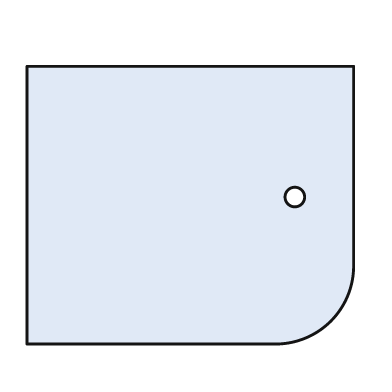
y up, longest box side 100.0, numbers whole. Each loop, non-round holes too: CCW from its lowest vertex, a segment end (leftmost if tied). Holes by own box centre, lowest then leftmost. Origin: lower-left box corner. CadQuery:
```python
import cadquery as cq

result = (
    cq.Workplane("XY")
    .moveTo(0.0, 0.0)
    .lineTo(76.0, 0.0)
    .threePointArc((93.0, 7.0), (100.0, 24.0))
    .lineTo(100.0, 85.0)
    .lineTo(0.0, 85.0)
    .close()
    .moveTo(82.0, 45.0)
    .circle(3.0)
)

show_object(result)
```